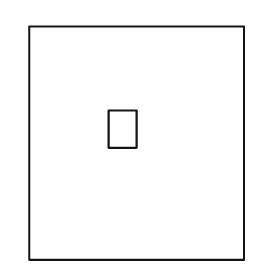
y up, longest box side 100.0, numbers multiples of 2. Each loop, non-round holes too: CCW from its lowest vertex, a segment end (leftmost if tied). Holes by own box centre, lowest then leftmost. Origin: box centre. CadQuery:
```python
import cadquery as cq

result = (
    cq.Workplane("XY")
    .moveTo(-46.0, -50.0)
    .lineTo(46.0, -50.0)
    .lineTo(46.0, 50.0)
    .lineTo(-46.0, 50.0)
    .close()
    .moveTo(-12.0, -2.0)
    .lineTo(0.0, -2.0)
    .lineTo(0.0, 14.0)
    .lineTo(-12.0, 14.0)
    .close()
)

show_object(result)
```